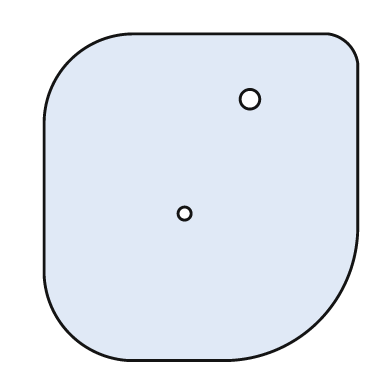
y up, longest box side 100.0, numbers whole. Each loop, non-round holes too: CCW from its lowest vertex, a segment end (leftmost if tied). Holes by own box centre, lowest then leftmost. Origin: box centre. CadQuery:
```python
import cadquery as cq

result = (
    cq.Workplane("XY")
    .moveTo(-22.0, -50.0)
    .lineTo(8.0, -50.0)
    .threePointArc((36.0, -38.0), (48.0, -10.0))
    .lineTo(48.0, 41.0)
    .threePointArc((45.0, 47.0), (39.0, 50.0))
    .lineTo(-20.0, 50.0)
    .threePointArc((-40.0, 42.0), (-48.0, 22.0))
    .lineTo(-48.0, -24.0)
    .threePointArc((-40.0, -42.0), (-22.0, -50.0))
    .close()
    .moveTo(-5.0, -5.0)
    .circle(2.0)
    .moveTo(15.0, 30.0)
    .circle(3.0)
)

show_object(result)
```